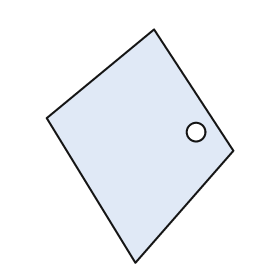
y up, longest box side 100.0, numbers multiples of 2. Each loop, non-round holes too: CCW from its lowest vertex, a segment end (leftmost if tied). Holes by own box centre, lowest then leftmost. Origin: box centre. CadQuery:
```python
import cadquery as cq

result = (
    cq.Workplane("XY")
    .moveTo(-2.0, -50.0)
    .lineTo(40.0, -2.0)
    .lineTo(6.0, 50.0)
    .lineTo(-40.0, 12.0)
    .close()
    .moveTo(24.0, 6.0)
    .circle(4.0)
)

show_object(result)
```